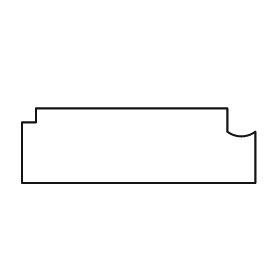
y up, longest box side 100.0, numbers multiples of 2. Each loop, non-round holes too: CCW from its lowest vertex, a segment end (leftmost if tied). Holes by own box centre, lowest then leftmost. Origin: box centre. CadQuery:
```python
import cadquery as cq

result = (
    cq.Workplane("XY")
    .moveTo(-50.0, -16.0)
    .lineTo(50.0, -16.0)
    .lineTo(50.0, 6.0)
    .threePointArc((44.0, 4.0), (38.0, 6.0))
    .lineTo(38.0, 16.0)
    .lineTo(-44.0, 16.0)
    .lineTo(-44.0, 10.0)
    .lineTo(-50.0, 10.0)
    .close()
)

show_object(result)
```